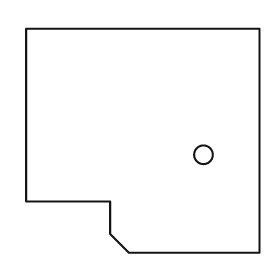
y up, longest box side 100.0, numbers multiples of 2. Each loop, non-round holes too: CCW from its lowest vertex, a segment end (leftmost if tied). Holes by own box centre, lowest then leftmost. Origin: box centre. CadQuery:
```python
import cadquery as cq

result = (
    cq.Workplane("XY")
    .moveTo(-6.0, -48.0)
    .lineTo(50.0, -48.0)
    .lineTo(50.0, 48.0)
    .lineTo(-50.0, 48.0)
    .lineTo(-50.0, -26.0)
    .lineTo(-14.0, -26.0)
    .lineTo(-14.0, -40.0)
    .close()
    .moveTo(26.0, -6.0)
    .circle(4.0)
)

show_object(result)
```